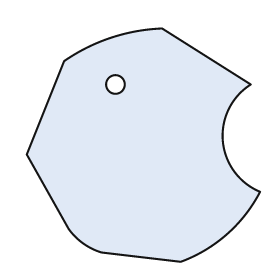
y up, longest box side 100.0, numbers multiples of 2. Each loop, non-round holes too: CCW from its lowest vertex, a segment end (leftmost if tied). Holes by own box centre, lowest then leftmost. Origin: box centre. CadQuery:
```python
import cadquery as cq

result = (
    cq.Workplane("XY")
    .moveTo(16.0, -50.0)
    .threePointArc((36.0, -38.0), (50.0, -20.0))
    .threePointArc((34.0, 2.0), (46.0, 26.0))
    .lineTo(8.0, 50.0)
    .threePointArc((-14.0, 46.0), (-34.0, 36.0))
    .lineTo(-50.0, -4.0)
    .lineTo(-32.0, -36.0)
    .threePointArc((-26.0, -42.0), (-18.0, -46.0))
    .close()
    .moveTo(-12.0, 26.0)
    .circle(4.0)
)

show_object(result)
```